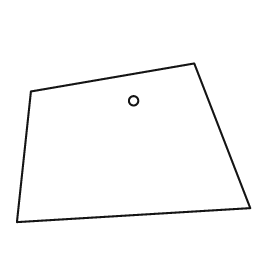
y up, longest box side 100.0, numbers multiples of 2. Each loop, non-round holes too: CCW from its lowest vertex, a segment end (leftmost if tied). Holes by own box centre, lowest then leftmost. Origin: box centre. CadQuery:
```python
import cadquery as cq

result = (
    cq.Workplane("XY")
    .moveTo(-50.0, -34.0)
    .lineTo(50.0, -28.0)
    .lineTo(26.0, 34.0)
    .lineTo(-44.0, 22.0)
    .close()
    .moveTo(0.0, 18.0)
    .circle(2.0)
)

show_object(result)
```